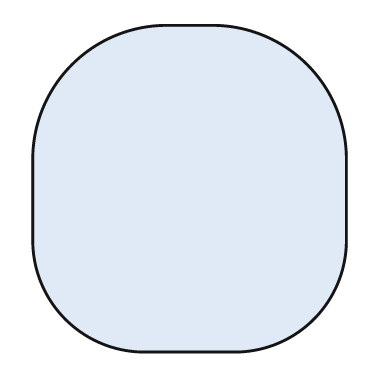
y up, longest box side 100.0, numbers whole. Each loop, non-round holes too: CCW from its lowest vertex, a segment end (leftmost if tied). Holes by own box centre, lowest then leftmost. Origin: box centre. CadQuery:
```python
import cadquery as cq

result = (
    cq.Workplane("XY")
    .moveTo(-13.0, -50.0)
    .lineTo(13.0, -50.0)
    .threePointArc((38.0, -40.0), (48.0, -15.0))
    .lineTo(48.0, 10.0)
    .threePointArc((36.0, 38.0), (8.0, 50.0))
    .lineTo(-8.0, 50.0)
    .threePointArc((-36.0, 38.0), (-48.0, 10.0))
    .lineTo(-48.0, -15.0)
    .threePointArc((-38.0, -40.0), (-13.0, -50.0))
    .close()
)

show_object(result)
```